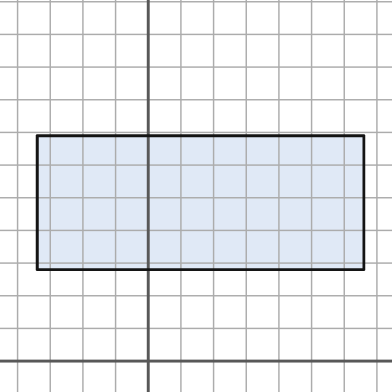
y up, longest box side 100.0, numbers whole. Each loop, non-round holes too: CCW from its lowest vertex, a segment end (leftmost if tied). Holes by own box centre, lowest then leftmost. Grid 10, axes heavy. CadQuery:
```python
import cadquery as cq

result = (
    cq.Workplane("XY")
    .moveTo(-34.0, 28.0)
    .lineTo(66.0, 28.0)
    .lineTo(66.0, 69.0)
    .lineTo(-34.0, 69.0)
    .close()
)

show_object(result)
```